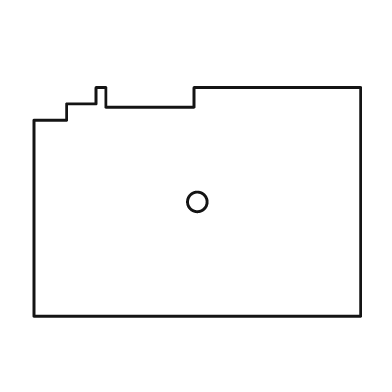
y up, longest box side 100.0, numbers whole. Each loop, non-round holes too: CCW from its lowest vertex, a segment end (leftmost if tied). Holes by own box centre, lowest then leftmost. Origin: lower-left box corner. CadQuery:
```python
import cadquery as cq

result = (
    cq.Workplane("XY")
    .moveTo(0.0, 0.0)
    .lineTo(100.0, 0.0)
    .lineTo(100.0, 70.0)
    .lineTo(49.0, 70.0)
    .lineTo(49.0, 64.0)
    .lineTo(22.0, 64.0)
    .lineTo(22.0, 70.0)
    .lineTo(19.0, 70.0)
    .lineTo(19.0, 65.0)
    .lineTo(10.0, 65.0)
    .lineTo(10.0, 60.0)
    .lineTo(0.0, 60.0)
    .close()
    .moveTo(50.0, 35.0)
    .circle(3.0)
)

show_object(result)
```